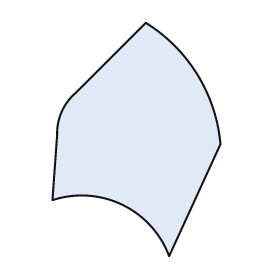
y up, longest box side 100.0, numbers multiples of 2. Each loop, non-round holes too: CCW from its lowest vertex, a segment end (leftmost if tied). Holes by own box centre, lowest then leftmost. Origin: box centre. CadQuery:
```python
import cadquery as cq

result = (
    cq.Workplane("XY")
    .moveTo(14.0, -50.0)
    .lineTo(36.0, -2.0)
    .threePointArc((26.0, 28.0), (4.0, 50.0))
    .lineTo(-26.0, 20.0)
    .threePointArc((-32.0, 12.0), (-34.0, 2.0))
    .lineTo(-36.0, -26.0)
    .threePointArc((-6.0, -28.0), (14.0, -50.0))
    .close()
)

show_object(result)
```